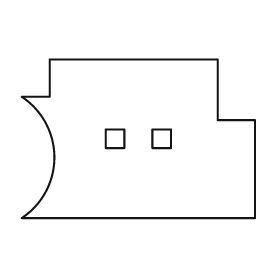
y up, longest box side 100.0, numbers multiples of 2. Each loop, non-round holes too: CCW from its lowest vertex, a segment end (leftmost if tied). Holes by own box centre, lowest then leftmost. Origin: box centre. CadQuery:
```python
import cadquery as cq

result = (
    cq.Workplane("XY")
    .moveTo(-50.0, -34.0)
    .lineTo(50.0, -34.0)
    .lineTo(50.0, 8.0)
    .lineTo(34.0, 8.0)
    .lineTo(34.0, 34.0)
    .lineTo(-38.0, 34.0)
    .lineTo(-38.0, 18.0)
    .lineTo(-50.0, 18.0)
    .threePointArc((-36.0, -8.0), (-50.0, -34.0))
    .close()
    .moveTo(-14.0, -4.0)
    .lineTo(-6.0, -4.0)
    .lineTo(-6.0, 4.0)
    .lineTo(-14.0, 4.0)
    .close()
    .moveTo(6.0, -4.0)
    .lineTo(14.0, -4.0)
    .lineTo(14.0, 4.0)
    .lineTo(6.0, 4.0)
    .close()
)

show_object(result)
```